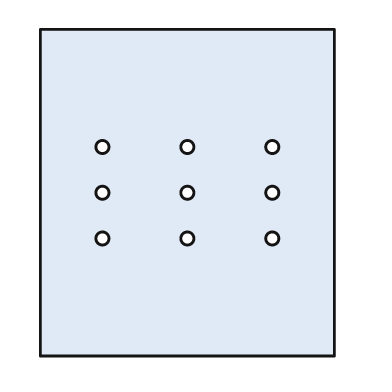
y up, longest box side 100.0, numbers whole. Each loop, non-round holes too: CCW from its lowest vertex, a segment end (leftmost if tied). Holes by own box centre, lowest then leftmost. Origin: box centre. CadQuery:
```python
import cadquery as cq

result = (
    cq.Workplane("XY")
    .moveTo(-45.0, -50.0)
    .lineTo(45.0, -50.0)
    .lineTo(45.0, 50.0)
    .lineTo(-45.0, 50.0)
    .close()
    .moveTo(-26.0, -14.0)
    .circle(2.0)
    .moveTo(0.0, -14.0)
    .circle(2.0)
    .moveTo(26.0, -14.0)
    .circle(2.0)
    .moveTo(-26.0, 0.0)
    .circle(2.0)
    .moveTo(0.0, 0.0)
    .circle(2.0)
    .moveTo(26.0, 0.0)
    .circle(2.0)
    .moveTo(-26.0, 14.0)
    .circle(2.0)
    .moveTo(0.0, 14.0)
    .circle(2.0)
    .moveTo(26.0, 14.0)
    .circle(2.0)
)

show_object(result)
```